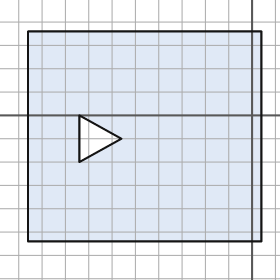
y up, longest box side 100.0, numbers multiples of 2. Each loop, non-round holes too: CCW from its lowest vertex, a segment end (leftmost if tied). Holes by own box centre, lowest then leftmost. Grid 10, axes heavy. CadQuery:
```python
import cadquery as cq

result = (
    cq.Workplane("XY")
    .moveTo(-96.0, -54.0)
    .lineTo(4.0, -54.0)
    .lineTo(4.0, 36.0)
    .lineTo(-96.0, 36.0)
    .close()
    .moveTo(-74.0, -20.0)
    .lineTo(-56.0, -10.0)
    .lineTo(-74.0, 0.0)
    .close()
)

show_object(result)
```